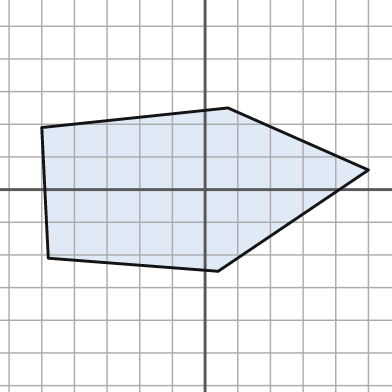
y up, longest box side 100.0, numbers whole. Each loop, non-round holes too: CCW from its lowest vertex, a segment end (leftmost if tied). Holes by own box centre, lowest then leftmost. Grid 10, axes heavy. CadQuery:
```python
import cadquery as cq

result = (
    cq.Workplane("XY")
    .moveTo(4.0, -25.0)
    .lineTo(50.0, 6.0)
    .lineTo(7.0, 25.0)
    .lineTo(-50.0, 19.0)
    .lineTo(-48.0, -21.0)
    .close()
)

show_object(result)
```